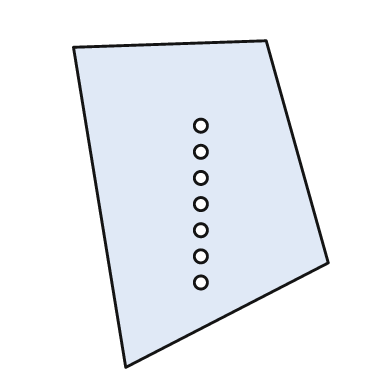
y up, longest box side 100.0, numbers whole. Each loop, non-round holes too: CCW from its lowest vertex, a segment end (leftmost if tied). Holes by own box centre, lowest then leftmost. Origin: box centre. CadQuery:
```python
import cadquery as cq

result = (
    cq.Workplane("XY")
    .moveTo(-23.0, -50.0)
    .lineTo(39.0, -18.0)
    .lineTo(20.0, 50.0)
    .lineTo(-39.0, 48.0)
    .close()
    .moveTo(0.0, -24.0)
    .circle(2.0)
    .moveTo(0.0, -16.0)
    .circle(2.0)
    .moveTo(0.0, -8.0)
    .circle(2.0)
    .moveTo(0.0, 0.0)
    .circle(2.0)
    .moveTo(0.0, 8.0)
    .circle(2.0)
    .moveTo(0.0, 16.0)
    .circle(2.0)
    .moveTo(0.0, 24.0)
    .circle(2.0)
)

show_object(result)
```